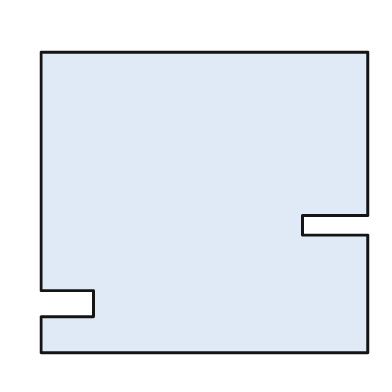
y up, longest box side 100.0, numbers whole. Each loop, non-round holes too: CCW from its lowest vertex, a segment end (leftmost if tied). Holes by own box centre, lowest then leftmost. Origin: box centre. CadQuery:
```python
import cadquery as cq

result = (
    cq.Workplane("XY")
    .moveTo(-50.0, -46.0)
    .lineTo(50.0, -46.0)
    .lineTo(50.0, -10.0)
    .lineTo(30.0, -10.0)
    .lineTo(30.0, -4.0)
    .lineTo(50.0, -4.0)
    .lineTo(50.0, 46.0)
    .lineTo(-50.0, 46.0)
    .lineTo(-50.0, -27.0)
    .lineTo(-34.0, -27.0)
    .lineTo(-34.0, -35.0)
    .lineTo(-50.0, -35.0)
    .close()
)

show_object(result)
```